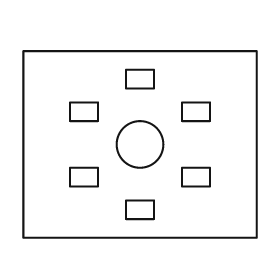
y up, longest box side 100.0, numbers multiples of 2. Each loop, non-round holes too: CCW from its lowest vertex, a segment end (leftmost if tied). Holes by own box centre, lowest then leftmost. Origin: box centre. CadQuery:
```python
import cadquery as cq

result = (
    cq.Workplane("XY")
    .moveTo(-50.0, -40.0)
    .lineTo(50.0, -40.0)
    .lineTo(50.0, 40.0)
    .lineTo(-50.0, 40.0)
    .close()
    .moveTo(-6.0, -32.0)
    .lineTo(6.0, -32.0)
    .lineTo(6.0, -24.0)
    .lineTo(-6.0, -24.0)
    .close()
    .moveTo(-30.0, -18.0)
    .lineTo(-18.0, -18.0)
    .lineTo(-18.0, -10.0)
    .lineTo(-30.0, -10.0)
    .close()
    .moveTo(18.0, -18.0)
    .lineTo(30.0, -18.0)
    .lineTo(30.0, -10.0)
    .lineTo(18.0, -10.0)
    .close()
    .moveTo(0.0, 0.0)
    .circle(10.0)
    .moveTo(-30.0, 10.0)
    .lineTo(-18.0, 10.0)
    .lineTo(-18.0, 18.0)
    .lineTo(-30.0, 18.0)
    .close()
    .moveTo(18.0, 10.0)
    .lineTo(30.0, 10.0)
    .lineTo(30.0, 18.0)
    .lineTo(18.0, 18.0)
    .close()
    .moveTo(-6.0, 24.0)
    .lineTo(6.0, 24.0)
    .lineTo(6.0, 32.0)
    .lineTo(-6.0, 32.0)
    .close()
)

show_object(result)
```